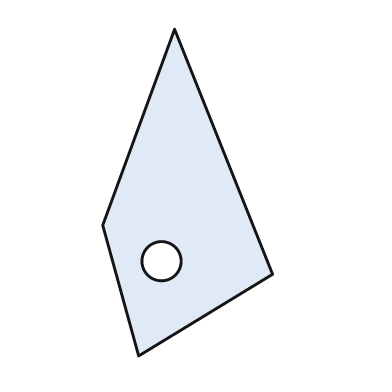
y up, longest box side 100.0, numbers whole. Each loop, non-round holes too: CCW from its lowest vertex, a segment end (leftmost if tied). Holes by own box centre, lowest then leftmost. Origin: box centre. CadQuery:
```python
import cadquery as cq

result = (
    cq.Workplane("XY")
    .moveTo(-15.0, -50.0)
    .lineTo(26.0, -25.0)
    .lineTo(-4.0, 50.0)
    .lineTo(-26.0, -10.0)
    .close()
    .moveTo(-8.0, -21.0)
    .circle(6.0)
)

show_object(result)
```